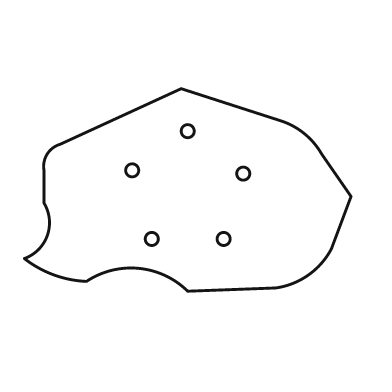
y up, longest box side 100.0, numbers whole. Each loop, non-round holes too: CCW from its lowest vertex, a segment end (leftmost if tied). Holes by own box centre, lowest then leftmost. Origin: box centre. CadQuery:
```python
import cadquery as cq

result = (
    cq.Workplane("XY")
    .moveTo(0.0, -31.0)
    .lineTo(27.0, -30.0)
    .threePointArc((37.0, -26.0), (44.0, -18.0))
    .lineTo(50.0, -2.0)
    .lineTo(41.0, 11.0)
    .threePointArc((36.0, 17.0), (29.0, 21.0))
    .lineTo(-2.0, 31.0)
    .lineTo(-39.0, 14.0)
    .threePointArc((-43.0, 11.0), (-44.0, 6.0))
    .lineTo(-44.0, -4.0)
    .threePointArc((-43.0, -14.0), (-50.0, -21.0))
    .threePointArc((-41.0, -26.0), (-31.0, -28.0))
    .threePointArc((-15.0, -24.0), (0.0, -31.0))
    .close()
    .moveTo(-11.0, -15.0)
    .circle(2.0)
    .moveTo(11.0, -15.0)
    .circle(2.0)
    .moveTo(17.0, 5.0)
    .circle(2.0)
    .moveTo(-17.0, 6.0)
    .circle(2.0)
    .moveTo(0.0, 18.0)
    .circle(2.0)
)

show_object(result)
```